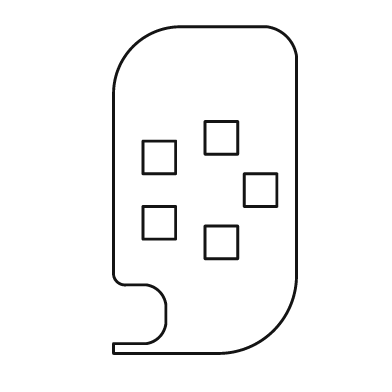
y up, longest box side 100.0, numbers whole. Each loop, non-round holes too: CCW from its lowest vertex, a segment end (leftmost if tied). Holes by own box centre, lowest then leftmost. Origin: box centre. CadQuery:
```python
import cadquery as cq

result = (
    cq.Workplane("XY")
    .moveTo(-28.0, -50.0)
    .lineTo(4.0, -50.0)
    .threePointArc((21.0, -43.0), (28.0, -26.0))
    .lineTo(28.0, 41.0)
    .threePointArc((25.0, 47.0), (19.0, 50.0))
    .lineTo(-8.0, 50.0)
    .threePointArc((-22.0, 44.0), (-28.0, 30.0))
    .lineTo(-28.0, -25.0)
    .threePointArc((-27.0, -28.0), (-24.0, -29.0))
    .lineTo(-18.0, -29.0)
    .threePointArc((-14.0, -31.0), (-12.0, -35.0))
    .lineTo(-12.0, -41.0)
    .threePointArc((-14.0, -45.0), (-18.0, -47.0))
    .lineTo(-28.0, -47.0)
    .close()
    .moveTo(0.0, -21.0)
    .lineTo(10.0, -21.0)
    .lineTo(10.0, -11.0)
    .lineTo(0.0, -11.0)
    .close()
    .moveTo(-19.0, -15.0)
    .lineTo(-9.0, -15.0)
    .lineTo(-9.0, -5.0)
    .lineTo(-19.0, -5.0)
    .close()
    .moveTo(12.0, -5.0)
    .lineTo(22.0, -5.0)
    .lineTo(22.0, 5.0)
    .lineTo(12.0, 5.0)
    .close()
    .moveTo(-19.0, 5.0)
    .lineTo(-9.0, 5.0)
    .lineTo(-9.0, 15.0)
    .lineTo(-19.0, 15.0)
    .close()
    .moveTo(0.0, 11.0)
    .lineTo(10.0, 11.0)
    .lineTo(10.0, 21.0)
    .lineTo(0.0, 21.0)
    .close()
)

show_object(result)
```